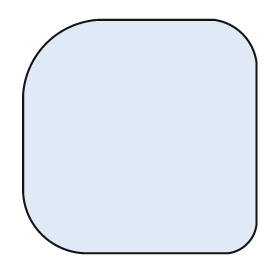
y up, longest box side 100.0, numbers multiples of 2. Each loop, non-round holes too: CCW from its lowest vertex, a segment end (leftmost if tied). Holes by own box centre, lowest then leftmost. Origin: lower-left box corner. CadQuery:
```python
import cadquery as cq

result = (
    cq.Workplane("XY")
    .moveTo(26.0, 0.0)
    .lineTo(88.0, 0.0)
    .threePointArc((96.0, 4.0), (100.0, 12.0))
    .lineTo(100.0, 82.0)
    .threePointArc((94.0, 94.0), (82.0, 100.0))
    .lineTo(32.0, 100.0)
    .threePointArc((10.0, 90.0), (0.0, 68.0))
    .lineTo(0.0, 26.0)
    .threePointArc((8.0, 8.0), (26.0, 0.0))
    .close()
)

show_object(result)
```